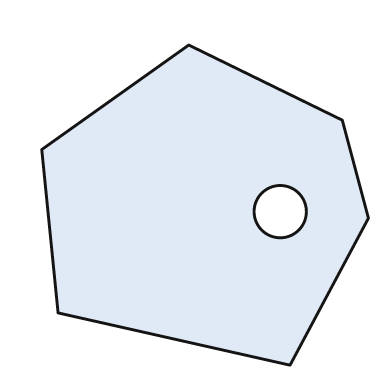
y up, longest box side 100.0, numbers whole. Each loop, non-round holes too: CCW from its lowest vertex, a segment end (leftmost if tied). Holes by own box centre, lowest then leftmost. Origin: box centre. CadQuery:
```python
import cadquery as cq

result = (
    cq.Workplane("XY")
    .moveTo(26.0, -49.0)
    .lineTo(50.0, -4.0)
    .lineTo(42.0, 26.0)
    .lineTo(-5.0, 49.0)
    .lineTo(-50.0, 17.0)
    .lineTo(-45.0, -33.0)
    .close()
    .moveTo(23.0, -2.0)
    .circle(8.0)
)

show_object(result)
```